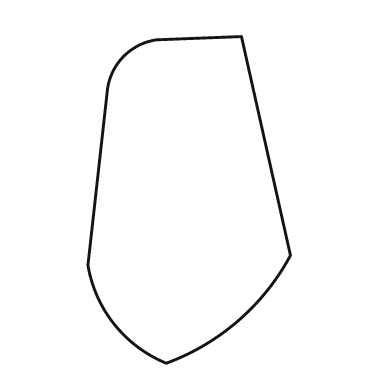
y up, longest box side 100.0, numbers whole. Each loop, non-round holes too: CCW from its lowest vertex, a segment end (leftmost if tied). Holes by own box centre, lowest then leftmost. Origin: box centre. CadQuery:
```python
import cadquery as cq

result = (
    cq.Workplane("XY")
    .moveTo(-7.0, -50.0)
    .threePointArc((15.0, -37.0), (31.0, -17.0))
    .lineTo(16.0, 50.0)
    .lineTo(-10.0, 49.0)
    .threePointArc((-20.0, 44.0), (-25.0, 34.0))
    .lineTo(-31.0, -20.0)
    .threePointArc((-23.0, -38.0), (-7.0, -50.0))
    .close()
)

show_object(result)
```